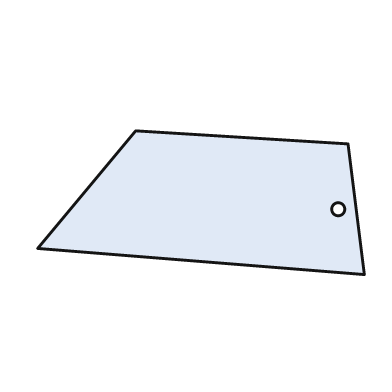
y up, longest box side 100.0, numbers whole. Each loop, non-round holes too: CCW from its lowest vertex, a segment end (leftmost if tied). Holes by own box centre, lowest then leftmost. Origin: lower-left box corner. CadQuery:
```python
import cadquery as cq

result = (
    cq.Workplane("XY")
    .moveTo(100.0, 0.0)
    .lineTo(95.0, 40.0)
    .lineTo(30.0, 44.0)
    .lineTo(0.0, 8.0)
    .close()
    .moveTo(92.0, 20.0)
    .circle(2.0)
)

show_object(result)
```